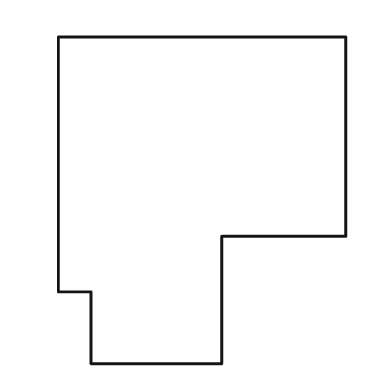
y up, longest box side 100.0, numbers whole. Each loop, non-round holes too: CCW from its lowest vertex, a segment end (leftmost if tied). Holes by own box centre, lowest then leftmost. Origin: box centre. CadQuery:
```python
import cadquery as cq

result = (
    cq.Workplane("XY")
    .moveTo(-34.0, -50.0)
    .lineTo(6.0, -50.0)
    .lineTo(6.0, -11.0)
    .lineTo(44.0, -11.0)
    .lineTo(44.0, 50.0)
    .lineTo(-44.0, 50.0)
    .lineTo(-44.0, -28.0)
    .lineTo(-34.0, -28.0)
    .close()
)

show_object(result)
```